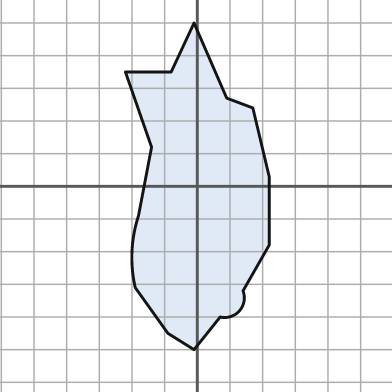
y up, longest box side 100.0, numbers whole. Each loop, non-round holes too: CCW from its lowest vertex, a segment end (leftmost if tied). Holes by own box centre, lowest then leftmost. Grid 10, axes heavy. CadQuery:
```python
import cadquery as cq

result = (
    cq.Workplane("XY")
    .moveTo(-1.0, -50.0)
    .lineTo(7.0, -40.0)
    .threePointArc((13.0, -38.0), (14.0, -32.0))
    .lineTo(22.0, -18.0)
    .lineTo(22.0, 3.0)
    .lineTo(17.0, 24.0)
    .lineTo(9.0, 27.0)
    .lineTo(-1.0, 50.0)
    .lineTo(-8.0, 35.0)
    .lineTo(-22.0, 35.0)
    .lineTo(-14.0, 12.0)
    .lineTo(-18.0, -9.0)
    .threePointArc((-20.0, -20.0), (-19.0, -31.0))
    .lineTo(-9.0, -45.0)
    .close()
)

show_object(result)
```